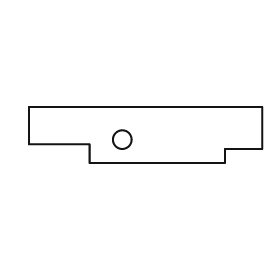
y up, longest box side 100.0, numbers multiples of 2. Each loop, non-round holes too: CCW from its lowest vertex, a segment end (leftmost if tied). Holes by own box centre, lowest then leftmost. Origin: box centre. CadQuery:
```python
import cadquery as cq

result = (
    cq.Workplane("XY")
    .moveTo(-24.0, -12.0)
    .lineTo(34.0, -12.0)
    .lineTo(34.0, -6.0)
    .lineTo(50.0, -6.0)
    .lineTo(50.0, 12.0)
    .lineTo(-50.0, 12.0)
    .lineTo(-50.0, -4.0)
    .lineTo(-24.0, -4.0)
    .close()
    .moveTo(-10.0, -2.0)
    .circle(4.0)
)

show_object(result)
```